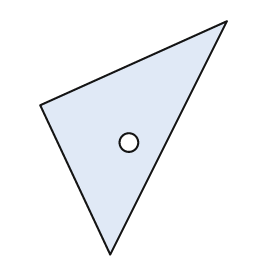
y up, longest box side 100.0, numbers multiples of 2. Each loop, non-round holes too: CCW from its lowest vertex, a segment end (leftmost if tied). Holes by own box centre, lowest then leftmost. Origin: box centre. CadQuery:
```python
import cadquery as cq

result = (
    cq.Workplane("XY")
    .moveTo(-10.0, -50.0)
    .lineTo(40.0, 50.0)
    .lineTo(-40.0, 14.0)
    .close()
    .moveTo(-2.0, -2.0)
    .circle(4.0)
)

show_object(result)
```